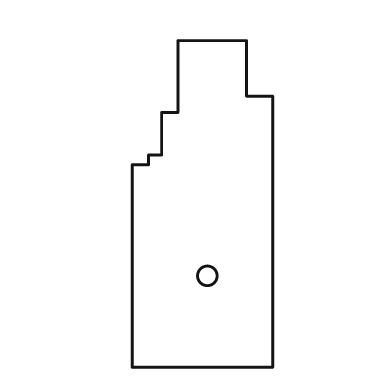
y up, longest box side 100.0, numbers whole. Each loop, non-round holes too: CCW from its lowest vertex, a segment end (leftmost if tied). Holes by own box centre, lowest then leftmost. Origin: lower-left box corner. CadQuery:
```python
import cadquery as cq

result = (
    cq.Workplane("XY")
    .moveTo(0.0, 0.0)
    .lineTo(43.0, 0.0)
    .lineTo(43.0, 83.0)
    .lineTo(35.0, 83.0)
    .lineTo(35.0, 100.0)
    .lineTo(14.0, 100.0)
    .lineTo(14.0, 78.0)
    .lineTo(9.0, 78.0)
    .lineTo(9.0, 65.0)
    .lineTo(5.0, 65.0)
    .lineTo(5.0, 62.0)
    .lineTo(0.0, 62.0)
    .close()
    .moveTo(23.0, 28.0)
    .circle(3.0)
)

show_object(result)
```